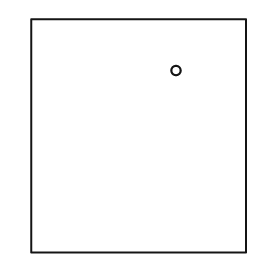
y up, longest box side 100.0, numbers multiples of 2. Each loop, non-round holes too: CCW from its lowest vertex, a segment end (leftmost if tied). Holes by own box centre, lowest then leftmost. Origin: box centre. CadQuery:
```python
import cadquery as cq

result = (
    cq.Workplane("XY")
    .moveTo(-46.0, -50.0)
    .lineTo(46.0, -50.0)
    .lineTo(46.0, 50.0)
    .lineTo(-46.0, 50.0)
    .close()
    .moveTo(16.0, 28.0)
    .circle(2.0)
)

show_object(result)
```